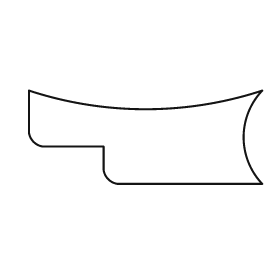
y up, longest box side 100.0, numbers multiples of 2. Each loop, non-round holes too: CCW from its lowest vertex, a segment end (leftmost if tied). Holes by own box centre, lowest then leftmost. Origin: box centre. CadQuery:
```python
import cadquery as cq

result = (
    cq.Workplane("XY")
    .moveTo(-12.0, -20.0)
    .lineTo(50.0, -20.0)
    .threePointArc((42.0, 0.0), (50.0, 20.0))
    .threePointArc((0.0, 12.0), (-50.0, 20.0))
    .lineTo(-50.0, 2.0)
    .threePointArc((-48.0, -2.0), (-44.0, -4.0))
    .lineTo(-18.0, -4.0)
    .lineTo(-18.0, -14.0)
    .threePointArc((-16.0, -18.0), (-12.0, -20.0))
    .close()
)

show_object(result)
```